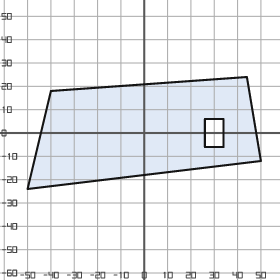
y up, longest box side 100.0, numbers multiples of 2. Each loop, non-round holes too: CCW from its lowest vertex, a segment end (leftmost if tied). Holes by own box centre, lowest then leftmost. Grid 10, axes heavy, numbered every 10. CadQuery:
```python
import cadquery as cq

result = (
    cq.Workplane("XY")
    .moveTo(-50.0, -24.0)
    .lineTo(50.0, -12.0)
    .lineTo(44.0, 24.0)
    .lineTo(-40.0, 18.0)
    .close()
    .moveTo(26.0, -6.0)
    .lineTo(34.0, -6.0)
    .lineTo(34.0, 6.0)
    .lineTo(26.0, 6.0)
    .close()
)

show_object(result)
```